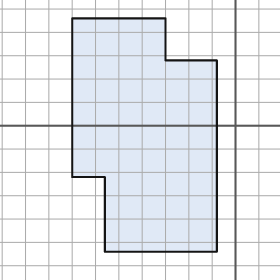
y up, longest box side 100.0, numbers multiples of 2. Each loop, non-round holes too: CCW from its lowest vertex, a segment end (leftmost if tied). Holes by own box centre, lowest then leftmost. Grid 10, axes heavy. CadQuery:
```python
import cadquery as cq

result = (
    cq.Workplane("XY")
    .moveTo(-56.0, -54.0)
    .lineTo(-8.0, -54.0)
    .lineTo(-8.0, 28.0)
    .lineTo(-30.0, 28.0)
    .lineTo(-30.0, 46.0)
    .lineTo(-70.0, 46.0)
    .lineTo(-70.0, -22.0)
    .lineTo(-56.0, -22.0)
    .close()
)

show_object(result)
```